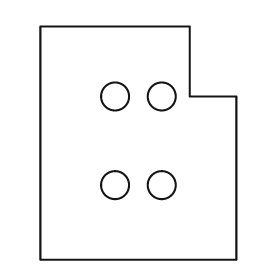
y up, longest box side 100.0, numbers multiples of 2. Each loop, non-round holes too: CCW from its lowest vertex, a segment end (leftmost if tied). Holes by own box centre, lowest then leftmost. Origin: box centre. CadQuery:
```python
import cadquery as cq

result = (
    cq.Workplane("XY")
    .moveTo(-42.0, -50.0)
    .lineTo(42.0, -50.0)
    .lineTo(42.0, 20.0)
    .lineTo(22.0, 20.0)
    .lineTo(22.0, 50.0)
    .lineTo(-42.0, 50.0)
    .close()
    .moveTo(-10.0, -18.0)
    .circle(6.0)
    .moveTo(10.0, -18.0)
    .circle(6.0)
    .moveTo(-10.0, 20.0)
    .circle(6.0)
    .moveTo(10.0, 20.0)
    .circle(6.0)
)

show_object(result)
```